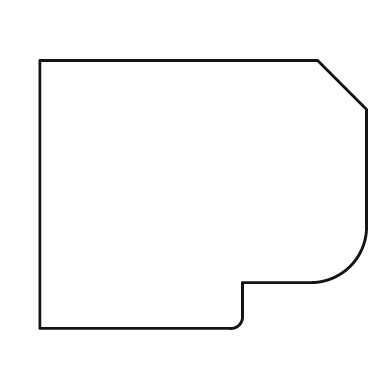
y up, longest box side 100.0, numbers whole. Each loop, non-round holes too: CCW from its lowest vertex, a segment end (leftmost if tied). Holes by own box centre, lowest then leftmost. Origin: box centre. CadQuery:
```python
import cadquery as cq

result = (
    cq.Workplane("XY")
    .moveTo(-50.0, -41.0)
    .lineTo(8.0, -41.0)
    .threePointArc((11.0, -40.0), (12.0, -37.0))
    .lineTo(12.0, -27.0)
    .lineTo(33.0, -27.0)
    .threePointArc((45.0, -22.0), (50.0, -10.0))
    .lineTo(50.0, 26.0)
    .lineTo(35.0, 41.0)
    .lineTo(-50.0, 41.0)
    .close()
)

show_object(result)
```